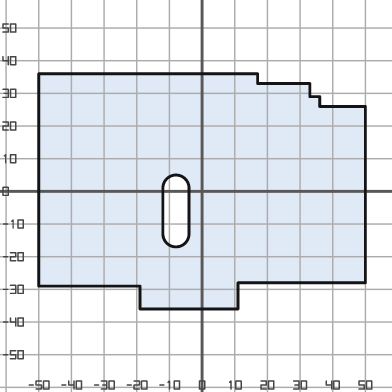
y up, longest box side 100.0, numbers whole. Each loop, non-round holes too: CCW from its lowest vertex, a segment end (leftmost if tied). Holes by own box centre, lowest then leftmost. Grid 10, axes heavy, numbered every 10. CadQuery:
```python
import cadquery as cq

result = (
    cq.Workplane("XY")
    .moveTo(-19.0, -36.0)
    .lineTo(11.0, -36.0)
    .lineTo(11.0, -28.0)
    .lineTo(50.0, -28.0)
    .lineTo(50.0, 26.0)
    .lineTo(36.0, 26.0)
    .lineTo(36.0, 29.0)
    .lineTo(33.0, 29.0)
    .lineTo(33.0, 33.0)
    .lineTo(17.0, 33.0)
    .lineTo(17.0, 36.0)
    .lineTo(-50.0, 36.0)
    .lineTo(-50.0, -29.0)
    .lineTo(-19.0, -29.0)
    .close()
    .moveTo(-12.0, -13.0)
    .threePointArc((-8.0, -17.0), (-4.0, -13.0))
    .lineTo(-4.0, 1.0)
    .threePointArc((-8.0, 5.0), (-12.0, 1.0))
    .close()
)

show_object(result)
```